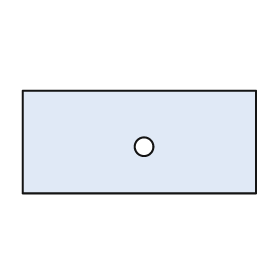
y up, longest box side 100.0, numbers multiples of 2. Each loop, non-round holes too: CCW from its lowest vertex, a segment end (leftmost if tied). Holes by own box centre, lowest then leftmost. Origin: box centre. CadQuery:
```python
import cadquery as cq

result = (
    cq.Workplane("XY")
    .moveTo(-50.0, -22.0)
    .lineTo(50.0, -22.0)
    .lineTo(50.0, 22.0)
    .lineTo(-50.0, 22.0)
    .close()
    .moveTo(2.0, -2.0)
    .circle(4.0)
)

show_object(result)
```